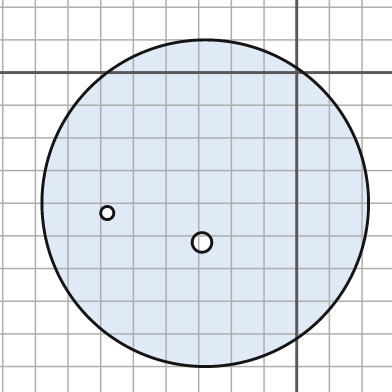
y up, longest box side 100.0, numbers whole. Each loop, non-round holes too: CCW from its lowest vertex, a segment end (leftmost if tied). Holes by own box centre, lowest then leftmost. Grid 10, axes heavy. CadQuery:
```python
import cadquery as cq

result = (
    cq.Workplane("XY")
    .moveTo(-28.0, -40.0)
    .circle(50.0)
    .moveTo(-29.0, -52.0)
    .circle(3.0)
    .moveTo(-58.0, -43.0)
    .circle(2.0)
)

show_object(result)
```